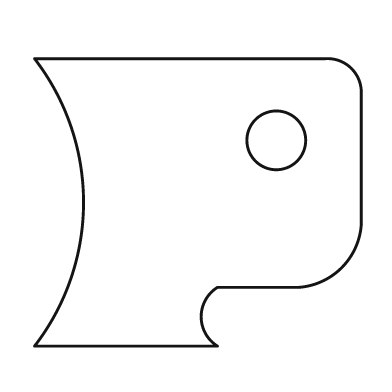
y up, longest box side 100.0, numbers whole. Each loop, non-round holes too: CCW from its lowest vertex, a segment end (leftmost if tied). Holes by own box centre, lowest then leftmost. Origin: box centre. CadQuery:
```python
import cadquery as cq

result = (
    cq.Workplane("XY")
    .moveTo(-50.0, -44.0)
    .lineTo(6.0, -44.0)
    .threePointArc((1.0, -35.0), (6.0, -26.0))
    .lineTo(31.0, -26.0)
    .threePointArc((44.0, -20.0), (50.0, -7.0))
    .lineTo(50.0, 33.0)
    .threePointArc((47.0, 41.0), (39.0, 44.0))
    .lineTo(-50.0, 44.0)
    .threePointArc((-35.0, 0.0), (-50.0, -44.0))
    .close()
    .moveTo(24.0, 19.0)
    .circle(9.0)
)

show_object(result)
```